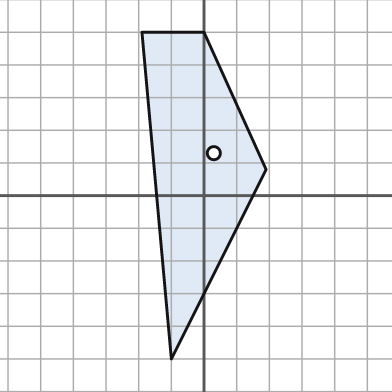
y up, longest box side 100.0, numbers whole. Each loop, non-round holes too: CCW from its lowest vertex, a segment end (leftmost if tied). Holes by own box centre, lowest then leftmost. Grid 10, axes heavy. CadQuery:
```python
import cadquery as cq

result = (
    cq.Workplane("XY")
    .moveTo(-10.0, -50.0)
    .lineTo(19.0, 8.0)
    .lineTo(0.0, 50.0)
    .lineTo(-19.0, 50.0)
    .close()
    .moveTo(3.0, 13.0)
    .circle(2.0)
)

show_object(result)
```